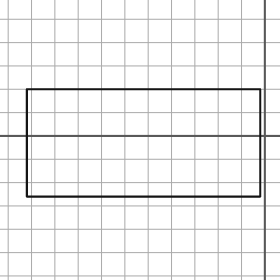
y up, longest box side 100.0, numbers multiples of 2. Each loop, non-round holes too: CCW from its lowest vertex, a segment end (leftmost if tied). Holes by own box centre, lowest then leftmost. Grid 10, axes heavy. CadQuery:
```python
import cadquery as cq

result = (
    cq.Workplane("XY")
    .moveTo(-102.0, -26.0)
    .lineTo(-2.0, -26.0)
    .lineTo(-2.0, 20.0)
    .lineTo(-102.0, 20.0)
    .close()
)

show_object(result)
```